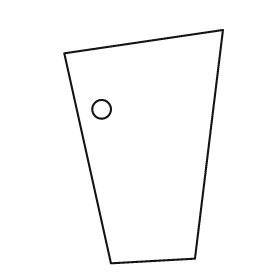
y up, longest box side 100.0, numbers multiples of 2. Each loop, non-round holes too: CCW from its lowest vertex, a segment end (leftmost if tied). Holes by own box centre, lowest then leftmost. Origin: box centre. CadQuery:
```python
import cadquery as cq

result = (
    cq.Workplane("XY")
    .moveTo(-14.0, -50.0)
    .lineTo(22.0, -48.0)
    .lineTo(34.0, 50.0)
    .lineTo(-34.0, 40.0)
    .close()
    .moveTo(-18.0, 16.0)
    .circle(4.0)
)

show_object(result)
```